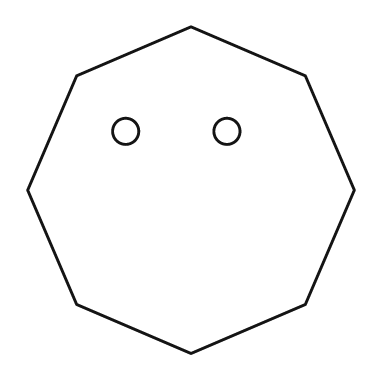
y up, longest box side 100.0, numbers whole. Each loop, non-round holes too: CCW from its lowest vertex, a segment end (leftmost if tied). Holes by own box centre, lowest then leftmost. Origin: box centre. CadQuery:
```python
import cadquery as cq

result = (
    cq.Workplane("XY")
    .moveTo(0.0, -50.0)
    .lineTo(35.0, -35.0)
    .lineTo(50.0, 0.0)
    .lineTo(35.0, 35.0)
    .lineTo(0.0, 50.0)
    .lineTo(-35.0, 35.0)
    .lineTo(-50.0, 0.0)
    .lineTo(-35.0, -35.0)
    .close()
    .moveTo(-20.0, 18.0)
    .circle(4.0)
    .moveTo(11.0, 18.0)
    .circle(4.0)
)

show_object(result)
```